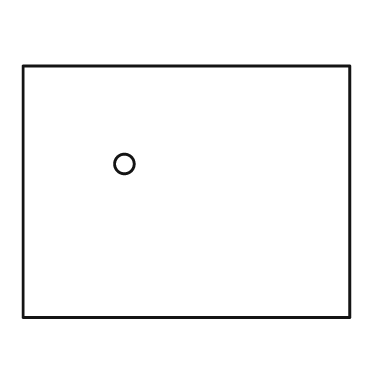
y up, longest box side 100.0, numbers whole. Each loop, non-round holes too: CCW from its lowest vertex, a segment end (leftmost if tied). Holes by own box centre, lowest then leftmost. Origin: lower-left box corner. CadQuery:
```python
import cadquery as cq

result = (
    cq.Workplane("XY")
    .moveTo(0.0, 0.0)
    .lineTo(100.0, 0.0)
    .lineTo(100.0, 77.0)
    .lineTo(0.0, 77.0)
    .close()
    .moveTo(31.0, 47.0)
    .circle(3.0)
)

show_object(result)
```